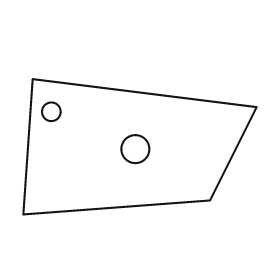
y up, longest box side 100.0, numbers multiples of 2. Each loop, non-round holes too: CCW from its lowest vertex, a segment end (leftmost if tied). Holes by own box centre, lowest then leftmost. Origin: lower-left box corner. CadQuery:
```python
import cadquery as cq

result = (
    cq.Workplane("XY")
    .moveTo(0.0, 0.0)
    .lineTo(80.0, 6.0)
    .lineTo(100.0, 46.0)
    .lineTo(4.0, 58.0)
    .close()
    .moveTo(48.0, 28.0)
    .circle(6.0)
    .moveTo(12.0, 44.0)
    .circle(4.0)
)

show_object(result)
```